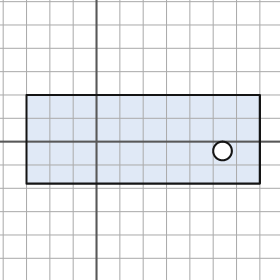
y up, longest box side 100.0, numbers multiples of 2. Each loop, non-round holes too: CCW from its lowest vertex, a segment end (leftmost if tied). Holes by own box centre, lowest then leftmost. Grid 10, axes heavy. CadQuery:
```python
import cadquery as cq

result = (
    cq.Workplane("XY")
    .moveTo(-30.0, -18.0)
    .lineTo(70.0, -18.0)
    .lineTo(70.0, 20.0)
    .lineTo(-30.0, 20.0)
    .close()
    .moveTo(54.0, -4.0)
    .circle(4.0)
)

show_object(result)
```